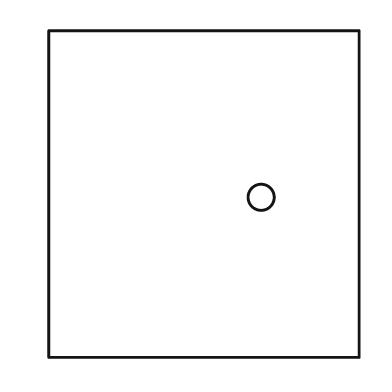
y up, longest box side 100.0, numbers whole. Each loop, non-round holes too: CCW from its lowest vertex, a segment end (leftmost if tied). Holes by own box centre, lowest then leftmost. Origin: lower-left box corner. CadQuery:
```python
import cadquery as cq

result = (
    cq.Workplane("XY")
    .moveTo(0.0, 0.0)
    .lineTo(95.0, 0.0)
    .lineTo(95.0, 100.0)
    .lineTo(0.0, 100.0)
    .close()
    .moveTo(65.0, 49.0)
    .circle(4.0)
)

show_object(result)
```